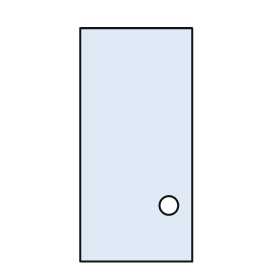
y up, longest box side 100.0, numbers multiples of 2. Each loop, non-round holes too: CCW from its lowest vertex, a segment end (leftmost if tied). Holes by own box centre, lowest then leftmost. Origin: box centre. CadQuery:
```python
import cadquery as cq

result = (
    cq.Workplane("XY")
    .moveTo(-24.0, -50.0)
    .lineTo(24.0, -50.0)
    .lineTo(24.0, 50.0)
    .lineTo(-24.0, 50.0)
    .close()
    .moveTo(14.0, -26.0)
    .circle(4.0)
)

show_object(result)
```